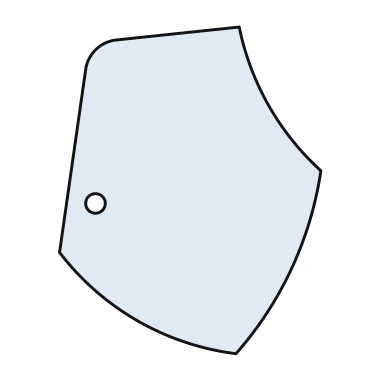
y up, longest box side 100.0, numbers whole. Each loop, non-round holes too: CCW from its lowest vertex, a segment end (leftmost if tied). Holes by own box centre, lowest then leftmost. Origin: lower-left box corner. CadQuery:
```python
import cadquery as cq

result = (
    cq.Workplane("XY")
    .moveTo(54.0, 0.0)
    .threePointArc((71.0, 26.0), (80.0, 56.0))
    .threePointArc((64.0, 76.0), (55.0, 100.0))
    .lineTo(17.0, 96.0)
    .threePointArc((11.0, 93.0), (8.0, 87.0))
    .lineTo(0.0, 31.0)
    .threePointArc((24.0, 10.0), (54.0, 0.0))
    .close()
    .moveTo(11.0, 46.0)
    .circle(3.0)
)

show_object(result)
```